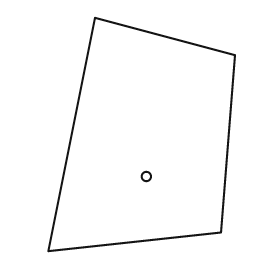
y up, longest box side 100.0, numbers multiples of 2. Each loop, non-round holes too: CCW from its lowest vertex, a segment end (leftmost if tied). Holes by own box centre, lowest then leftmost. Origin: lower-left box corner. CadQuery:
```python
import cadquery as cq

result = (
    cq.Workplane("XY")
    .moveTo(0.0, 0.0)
    .lineTo(74.0, 8.0)
    .lineTo(80.0, 84.0)
    .lineTo(20.0, 100.0)
    .close()
    .moveTo(42.0, 32.0)
    .circle(2.0)
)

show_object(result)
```